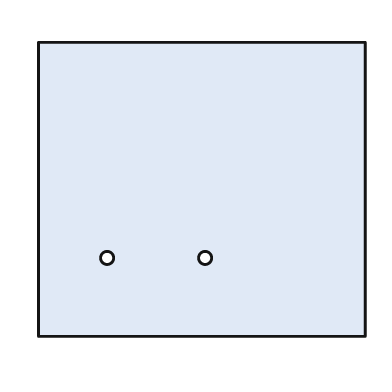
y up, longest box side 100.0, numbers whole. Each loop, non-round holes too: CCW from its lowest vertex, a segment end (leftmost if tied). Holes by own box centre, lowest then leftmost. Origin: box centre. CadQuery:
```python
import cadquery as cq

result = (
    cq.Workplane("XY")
    .moveTo(-50.0, -45.0)
    .lineTo(50.0, -45.0)
    .lineTo(50.0, 45.0)
    .lineTo(-50.0, 45.0)
    .close()
    .moveTo(-29.0, -21.0)
    .circle(2.0)
    .moveTo(1.0, -21.0)
    .circle(2.0)
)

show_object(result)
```